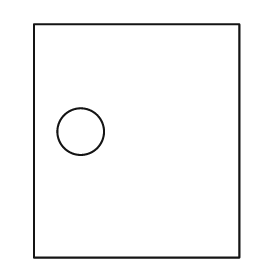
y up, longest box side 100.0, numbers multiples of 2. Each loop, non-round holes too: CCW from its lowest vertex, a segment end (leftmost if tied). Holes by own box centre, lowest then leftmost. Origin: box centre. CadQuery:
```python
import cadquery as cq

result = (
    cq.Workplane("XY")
    .moveTo(-44.0, -50.0)
    .lineTo(44.0, -50.0)
    .lineTo(44.0, 50.0)
    .lineTo(-44.0, 50.0)
    .close()
    .moveTo(-24.0, 4.0)
    .circle(10.0)
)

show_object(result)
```